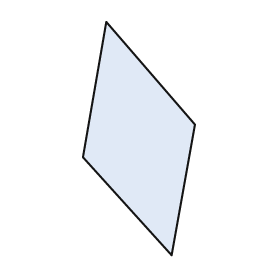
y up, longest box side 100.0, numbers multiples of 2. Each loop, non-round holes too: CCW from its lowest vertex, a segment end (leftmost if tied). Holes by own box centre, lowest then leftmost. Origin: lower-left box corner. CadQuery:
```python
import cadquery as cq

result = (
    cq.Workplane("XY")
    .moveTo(38.0, 0.0)
    .lineTo(48.0, 56.0)
    .lineTo(10.0, 100.0)
    .lineTo(0.0, 42.0)
    .close()
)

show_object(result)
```